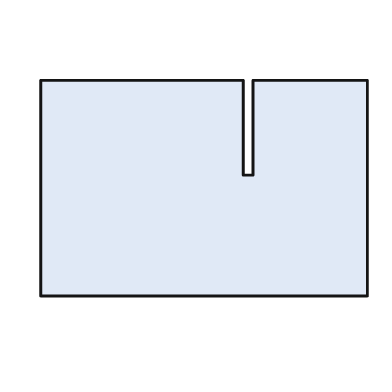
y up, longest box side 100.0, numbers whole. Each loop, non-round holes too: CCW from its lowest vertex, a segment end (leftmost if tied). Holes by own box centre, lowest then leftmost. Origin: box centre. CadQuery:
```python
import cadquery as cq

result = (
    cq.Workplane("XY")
    .moveTo(-50.0, -33.0)
    .lineTo(50.0, -33.0)
    .lineTo(50.0, 33.0)
    .lineTo(15.0, 33.0)
    .lineTo(15.0, 4.0)
    .lineTo(12.0, 4.0)
    .lineTo(12.0, 33.0)
    .lineTo(-50.0, 33.0)
    .close()
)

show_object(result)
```